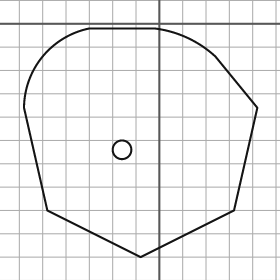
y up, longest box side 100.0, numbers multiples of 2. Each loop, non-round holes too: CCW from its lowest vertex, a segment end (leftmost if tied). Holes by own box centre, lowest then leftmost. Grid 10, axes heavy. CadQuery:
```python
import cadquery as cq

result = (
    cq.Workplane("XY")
    .moveTo(-8.0, -100.0)
    .lineTo(32.0, -80.0)
    .lineTo(42.0, -36.0)
    .lineTo(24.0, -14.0)
    .threePointArc((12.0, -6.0), (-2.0, -2.0))
    .lineTo(-30.0, -2.0)
    .threePointArc((-50.0, -14.0), (-58.0, -36.0))
    .lineTo(-48.0, -80.0)
    .close()
    .moveTo(-16.0, -54.0)
    .circle(4.0)
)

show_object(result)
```